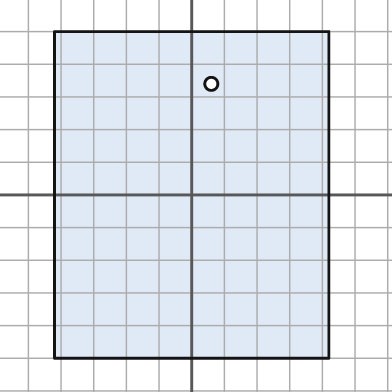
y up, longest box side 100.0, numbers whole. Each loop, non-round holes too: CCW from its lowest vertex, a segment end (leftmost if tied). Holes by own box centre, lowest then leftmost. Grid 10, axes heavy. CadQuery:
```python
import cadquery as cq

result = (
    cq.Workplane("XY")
    .moveTo(-42.0, -50.0)
    .lineTo(42.0, -50.0)
    .lineTo(42.0, 50.0)
    .lineTo(-42.0, 50.0)
    .close()
    .moveTo(6.0, 34.0)
    .circle(2.0)
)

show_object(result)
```